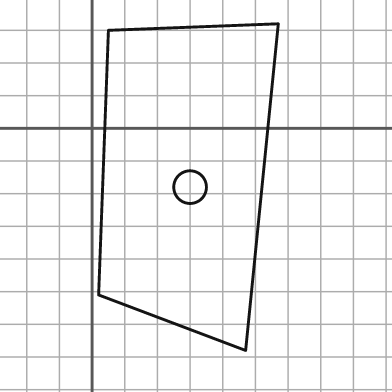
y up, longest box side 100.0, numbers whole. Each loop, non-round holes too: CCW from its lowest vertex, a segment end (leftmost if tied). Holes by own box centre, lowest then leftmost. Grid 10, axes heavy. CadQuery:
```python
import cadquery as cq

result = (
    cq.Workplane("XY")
    .moveTo(47.0, -68.0)
    .lineTo(57.0, 32.0)
    .lineTo(5.0, 30.0)
    .lineTo(2.0, -51.0)
    .close()
    .moveTo(30.0, -18.0)
    .circle(5.0)
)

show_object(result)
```